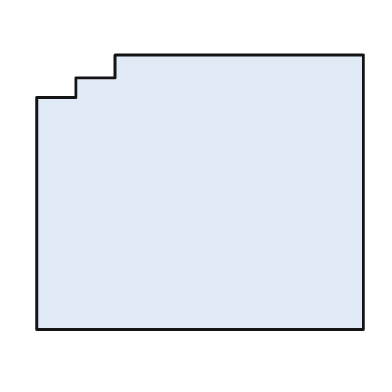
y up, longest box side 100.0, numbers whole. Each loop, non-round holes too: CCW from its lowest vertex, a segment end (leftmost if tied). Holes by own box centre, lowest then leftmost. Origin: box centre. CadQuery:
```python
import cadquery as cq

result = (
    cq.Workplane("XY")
    .moveTo(-50.0, -42.0)
    .lineTo(50.0, -42.0)
    .lineTo(50.0, 42.0)
    .lineTo(-26.0, 42.0)
    .lineTo(-26.0, 35.0)
    .lineTo(-38.0, 35.0)
    .lineTo(-38.0, 29.0)
    .lineTo(-50.0, 29.0)
    .close()
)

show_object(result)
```